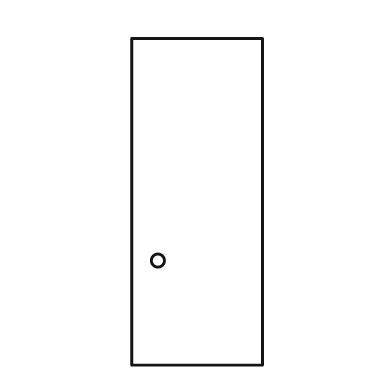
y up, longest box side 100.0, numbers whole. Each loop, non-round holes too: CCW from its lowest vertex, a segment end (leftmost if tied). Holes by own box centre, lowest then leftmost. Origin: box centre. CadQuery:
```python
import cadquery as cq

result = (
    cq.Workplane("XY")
    .moveTo(-20.0, -50.0)
    .lineTo(20.0, -50.0)
    .lineTo(20.0, 50.0)
    .lineTo(-20.0, 50.0)
    .close()
    .moveTo(-12.0, -18.0)
    .circle(2.0)
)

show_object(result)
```